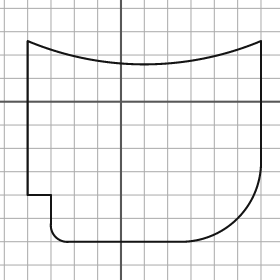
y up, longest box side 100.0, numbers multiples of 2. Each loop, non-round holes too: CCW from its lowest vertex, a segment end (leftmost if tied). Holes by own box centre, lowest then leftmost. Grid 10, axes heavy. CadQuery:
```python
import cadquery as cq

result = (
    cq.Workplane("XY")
    .moveTo(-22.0, -60.0)
    .lineTo(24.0, -60.0)
    .threePointArc((50.0, -50.0), (60.0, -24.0))
    .lineTo(60.0, 26.0)
    .threePointArc((10.0, 16.0), (-40.0, 26.0))
    .lineTo(-40.0, -40.0)
    .lineTo(-30.0, -40.0)
    .lineTo(-30.0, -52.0)
    .threePointArc((-28.0, -58.0), (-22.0, -60.0))
    .close()
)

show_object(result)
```